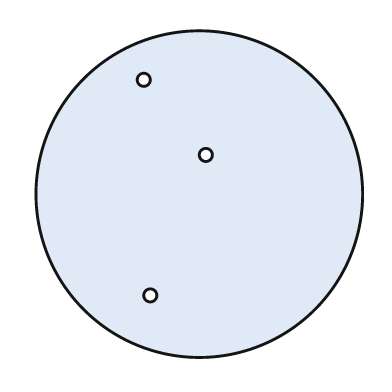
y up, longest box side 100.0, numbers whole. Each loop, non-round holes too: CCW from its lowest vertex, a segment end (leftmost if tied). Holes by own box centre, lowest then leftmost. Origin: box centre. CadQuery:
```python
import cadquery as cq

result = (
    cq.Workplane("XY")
    .moveTo(0.0, 0.0)
    .circle(50.0)
    .moveTo(-15.0, -31.0)
    .circle(2.0)
    .moveTo(2.0, 12.0)
    .circle(2.0)
    .moveTo(-17.0, 35.0)
    .circle(2.0)
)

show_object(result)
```